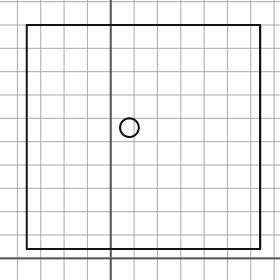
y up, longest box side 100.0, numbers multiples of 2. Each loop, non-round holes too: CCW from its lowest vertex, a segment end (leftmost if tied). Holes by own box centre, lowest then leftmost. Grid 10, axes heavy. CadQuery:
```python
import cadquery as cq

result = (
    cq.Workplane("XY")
    .moveTo(-36.0, 4.0)
    .lineTo(64.0, 4.0)
    .lineTo(64.0, 100.0)
    .lineTo(-36.0, 100.0)
    .close()
    .moveTo(8.0, 56.0)
    .circle(4.0)
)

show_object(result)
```